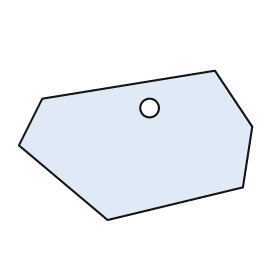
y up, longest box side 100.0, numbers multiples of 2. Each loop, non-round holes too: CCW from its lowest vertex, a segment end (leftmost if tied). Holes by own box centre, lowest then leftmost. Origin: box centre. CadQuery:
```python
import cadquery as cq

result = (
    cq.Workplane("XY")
    .moveTo(-12.0, -32.0)
    .lineTo(46.0, -18.0)
    .lineTo(50.0, 8.0)
    .lineTo(34.0, 32.0)
    .lineTo(-40.0, 20.0)
    .lineTo(-50.0, 0.0)
    .close()
    .moveTo(6.0, 16.0)
    .circle(4.0)
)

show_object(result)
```